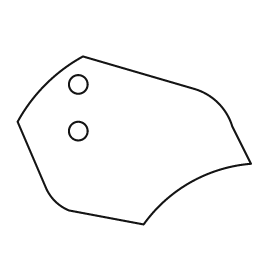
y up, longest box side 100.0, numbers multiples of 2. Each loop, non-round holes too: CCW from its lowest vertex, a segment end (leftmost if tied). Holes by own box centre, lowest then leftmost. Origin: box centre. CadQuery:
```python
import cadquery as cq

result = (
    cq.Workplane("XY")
    .moveTo(4.0, -36.0)
    .threePointArc((24.0, -18.0), (50.0, -10.0))
    .lineTo(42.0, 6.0)
    .threePointArc((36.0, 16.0), (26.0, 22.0))
    .lineTo(-22.0, 36.0)
    .threePointArc((-38.0, 24.0), (-50.0, 8.0))
    .lineTo(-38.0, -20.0)
    .threePointArc((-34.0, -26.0), (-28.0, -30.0))
    .close()
    .moveTo(-24.0, 4.0)
    .circle(4.0)
    .moveTo(-24.0, 24.0)
    .circle(4.0)
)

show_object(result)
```